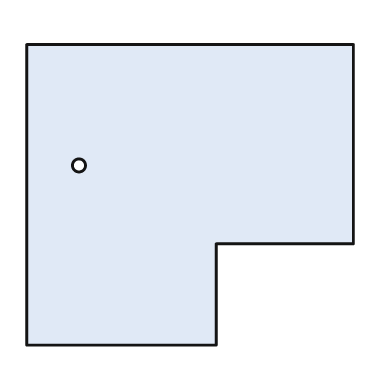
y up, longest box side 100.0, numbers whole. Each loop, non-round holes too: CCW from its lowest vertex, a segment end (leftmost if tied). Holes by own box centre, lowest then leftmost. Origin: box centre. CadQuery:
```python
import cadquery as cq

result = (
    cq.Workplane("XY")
    .moveTo(-50.0, -46.0)
    .lineTo(8.0, -46.0)
    .lineTo(8.0, -15.0)
    .lineTo(50.0, -15.0)
    .lineTo(50.0, 46.0)
    .lineTo(-50.0, 46.0)
    .close()
    .moveTo(-34.0, 9.0)
    .circle(2.0)
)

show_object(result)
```